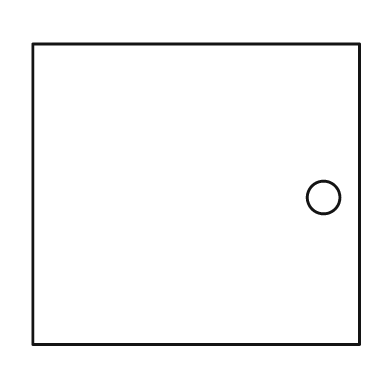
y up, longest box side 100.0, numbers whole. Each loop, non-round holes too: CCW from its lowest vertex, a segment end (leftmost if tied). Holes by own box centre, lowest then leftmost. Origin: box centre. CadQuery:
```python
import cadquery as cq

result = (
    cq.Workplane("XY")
    .moveTo(-50.0, -46.0)
    .lineTo(50.0, -46.0)
    .lineTo(50.0, 46.0)
    .lineTo(-50.0, 46.0)
    .close()
    .moveTo(39.0, -1.0)
    .circle(5.0)
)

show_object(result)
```